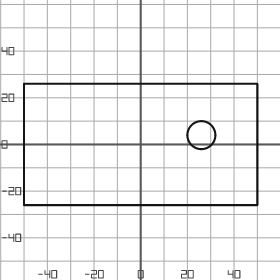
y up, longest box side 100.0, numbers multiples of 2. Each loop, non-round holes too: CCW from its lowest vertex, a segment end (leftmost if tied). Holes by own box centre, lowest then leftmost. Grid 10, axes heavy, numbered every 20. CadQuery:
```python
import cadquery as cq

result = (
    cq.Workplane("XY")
    .moveTo(-50.0, -26.0)
    .lineTo(50.0, -26.0)
    .lineTo(50.0, 26.0)
    .lineTo(-50.0, 26.0)
    .close()
    .moveTo(26.0, 4.0)
    .circle(6.0)
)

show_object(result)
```